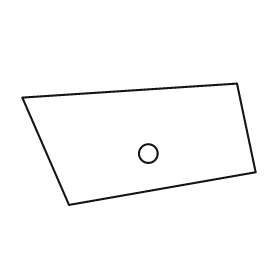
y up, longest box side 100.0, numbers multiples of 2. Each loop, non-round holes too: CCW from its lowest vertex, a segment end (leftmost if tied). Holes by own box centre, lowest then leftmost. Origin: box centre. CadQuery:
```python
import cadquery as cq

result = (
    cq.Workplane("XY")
    .moveTo(-30.0, -26.0)
    .lineTo(50.0, -12.0)
    .lineTo(42.0, 26.0)
    .lineTo(-50.0, 20.0)
    .close()
    .moveTo(4.0, -4.0)
    .circle(4.0)
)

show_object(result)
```